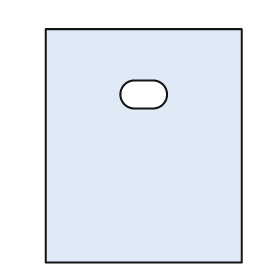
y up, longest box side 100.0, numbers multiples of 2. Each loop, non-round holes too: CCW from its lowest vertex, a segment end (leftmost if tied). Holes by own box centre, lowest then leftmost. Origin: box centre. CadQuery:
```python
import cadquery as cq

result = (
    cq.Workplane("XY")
    .moveTo(-42.0, -50.0)
    .lineTo(42.0, -50.0)
    .lineTo(42.0, 50.0)
    .lineTo(-42.0, 50.0)
    .close()
    .moveTo(-4.0, 16.0)
    .lineTo(4.0, 16.0)
    .threePointArc((10.0, 22.0), (4.0, 28.0))
    .lineTo(-4.0, 28.0)
    .threePointArc((-10.0, 22.0), (-4.0, 16.0))
    .close()
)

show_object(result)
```